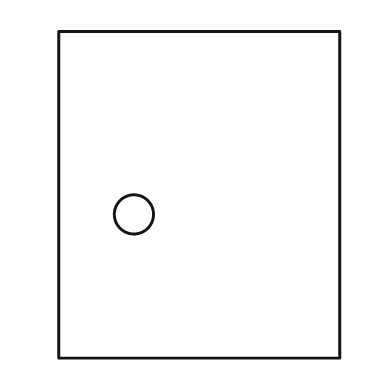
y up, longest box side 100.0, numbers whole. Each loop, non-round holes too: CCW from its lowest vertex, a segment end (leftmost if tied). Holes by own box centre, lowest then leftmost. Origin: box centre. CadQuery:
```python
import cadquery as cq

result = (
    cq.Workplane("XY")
    .moveTo(-43.0, -50.0)
    .lineTo(43.0, -50.0)
    .lineTo(43.0, 50.0)
    .lineTo(-43.0, 50.0)
    .close()
    .moveTo(-20.0, -6.0)
    .circle(6.0)
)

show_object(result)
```